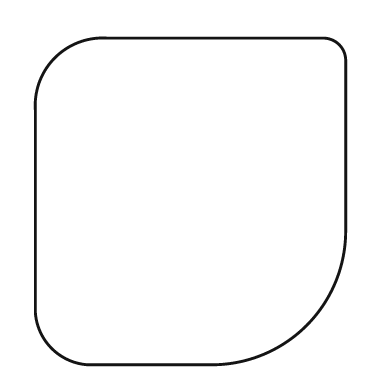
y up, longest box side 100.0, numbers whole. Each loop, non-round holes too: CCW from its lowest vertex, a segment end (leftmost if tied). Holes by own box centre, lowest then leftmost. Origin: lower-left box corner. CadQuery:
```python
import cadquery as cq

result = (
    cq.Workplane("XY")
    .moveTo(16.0, 0.0)
    .lineTo(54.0, 0.0)
    .threePointArc((83.0, 12.0), (95.0, 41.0))
    .lineTo(95.0, 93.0)
    .threePointArc((93.0, 98.0), (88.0, 100.0))
    .lineTo(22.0, 100.0)
    .threePointArc((6.0, 94.0), (0.0, 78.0))
    .lineTo(0.0, 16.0)
    .threePointArc((5.0, 5.0), (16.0, 0.0))
    .close()
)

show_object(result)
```